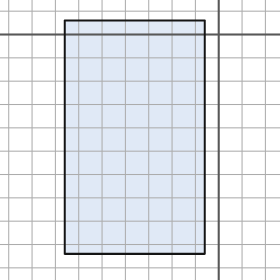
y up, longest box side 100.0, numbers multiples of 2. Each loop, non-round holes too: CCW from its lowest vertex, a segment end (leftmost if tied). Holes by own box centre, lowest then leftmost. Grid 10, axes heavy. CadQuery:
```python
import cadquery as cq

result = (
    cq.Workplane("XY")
    .moveTo(-66.0, -94.0)
    .lineTo(-6.0, -94.0)
    .lineTo(-6.0, 6.0)
    .lineTo(-66.0, 6.0)
    .close()
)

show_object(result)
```